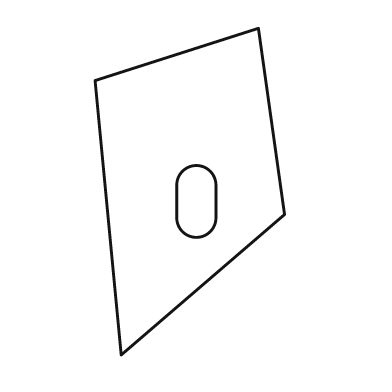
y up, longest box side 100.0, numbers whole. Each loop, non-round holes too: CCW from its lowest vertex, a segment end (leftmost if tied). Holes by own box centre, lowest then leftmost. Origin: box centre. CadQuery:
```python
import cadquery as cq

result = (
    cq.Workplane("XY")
    .moveTo(-21.0, -50.0)
    .lineTo(29.0, -7.0)
    .lineTo(21.0, 50.0)
    .lineTo(-29.0, 34.0)
    .close()
    .moveTo(-4.0, -8.0)
    .threePointArc((2.0, -14.0), (8.0, -8.0))
    .lineTo(8.0, 2.0)
    .threePointArc((2.0, 8.0), (-4.0, 2.0))
    .close()
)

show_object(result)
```